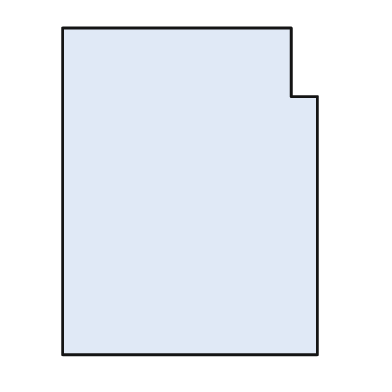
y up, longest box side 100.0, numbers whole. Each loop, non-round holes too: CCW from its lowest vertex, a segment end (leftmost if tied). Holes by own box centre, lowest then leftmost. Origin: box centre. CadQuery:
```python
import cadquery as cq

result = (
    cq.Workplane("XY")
    .moveTo(-39.0, -50.0)
    .lineTo(39.0, -50.0)
    .lineTo(39.0, 29.0)
    .lineTo(31.0, 29.0)
    .lineTo(31.0, 50.0)
    .lineTo(-39.0, 50.0)
    .close()
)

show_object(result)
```